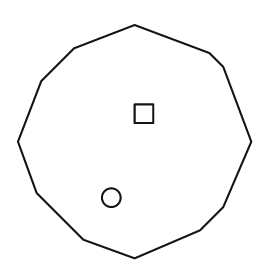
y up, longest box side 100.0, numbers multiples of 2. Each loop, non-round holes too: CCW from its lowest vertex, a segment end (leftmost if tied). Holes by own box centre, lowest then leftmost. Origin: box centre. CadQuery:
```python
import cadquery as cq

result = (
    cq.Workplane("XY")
    .moveTo(0.0, -50.0)
    .lineTo(28.0, -38.0)
    .lineTo(38.0, -28.0)
    .lineTo(50.0, 0.0)
    .lineTo(38.0, 32.0)
    .lineTo(32.0, 38.0)
    .lineTo(0.0, 50.0)
    .lineTo(-26.0, 40.0)
    .lineTo(-40.0, 26.0)
    .lineTo(-50.0, 0.0)
    .lineTo(-42.0, -22.0)
    .lineTo(-22.0, -42.0)
    .close()
    .moveTo(-10.0, -24.0)
    .circle(4.0)
    .moveTo(0.0, 8.0)
    .lineTo(8.0, 8.0)
    .lineTo(8.0, 16.0)
    .lineTo(0.0, 16.0)
    .close()
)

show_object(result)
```